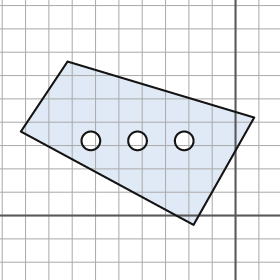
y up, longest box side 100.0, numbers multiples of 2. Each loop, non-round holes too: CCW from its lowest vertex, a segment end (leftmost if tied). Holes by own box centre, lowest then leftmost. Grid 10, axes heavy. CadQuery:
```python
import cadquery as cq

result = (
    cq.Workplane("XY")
    .moveTo(-18.0, -4.0)
    .lineTo(8.0, 42.0)
    .lineTo(-72.0, 66.0)
    .lineTo(-92.0, 36.0)
    .close()
    .moveTo(-62.0, 32.0)
    .circle(4.0)
    .moveTo(-42.0, 32.0)
    .circle(4.0)
    .moveTo(-22.0, 32.0)
    .circle(4.0)
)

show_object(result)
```